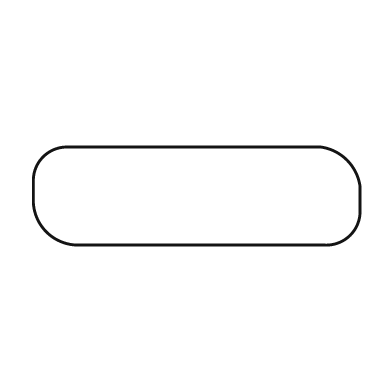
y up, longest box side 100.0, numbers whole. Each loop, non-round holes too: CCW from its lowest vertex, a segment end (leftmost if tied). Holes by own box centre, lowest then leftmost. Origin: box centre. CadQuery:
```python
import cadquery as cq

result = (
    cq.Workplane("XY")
    .moveTo(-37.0, -15.0)
    .lineTo(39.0, -15.0)
    .threePointArc((47.0, -12.0), (50.0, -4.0))
    .lineTo(50.0, 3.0)
    .threePointArc((46.0, 11.0), (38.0, 15.0))
    .lineTo(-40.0, 15.0)
    .threePointArc((-47.0, 12.0), (-50.0, 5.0))
    .lineTo(-50.0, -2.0)
    .threePointArc((-46.0, -11.0), (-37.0, -15.0))
    .close()
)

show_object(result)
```